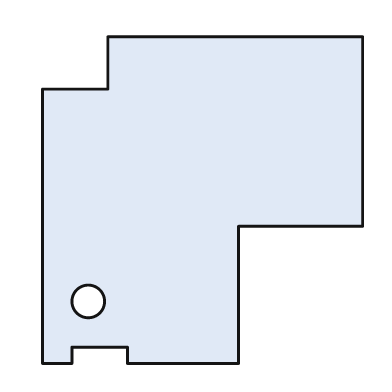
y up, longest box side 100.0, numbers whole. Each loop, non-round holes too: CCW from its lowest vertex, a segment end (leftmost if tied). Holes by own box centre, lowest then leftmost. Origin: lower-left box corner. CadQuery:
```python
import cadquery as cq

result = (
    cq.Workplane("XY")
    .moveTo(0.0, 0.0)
    .lineTo(9.0, 0.0)
    .lineTo(9.0, 5.0)
    .lineTo(26.0, 5.0)
    .lineTo(26.0, 0.0)
    .lineTo(60.0, 0.0)
    .lineTo(60.0, 42.0)
    .lineTo(98.0, 42.0)
    .lineTo(98.0, 100.0)
    .lineTo(20.0, 100.0)
    .lineTo(20.0, 84.0)
    .lineTo(0.0, 84.0)
    .close()
    .moveTo(14.0, 19.0)
    .circle(5.0)
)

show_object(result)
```